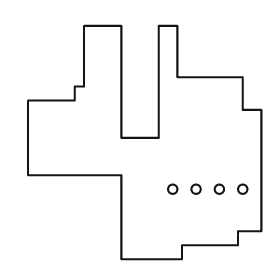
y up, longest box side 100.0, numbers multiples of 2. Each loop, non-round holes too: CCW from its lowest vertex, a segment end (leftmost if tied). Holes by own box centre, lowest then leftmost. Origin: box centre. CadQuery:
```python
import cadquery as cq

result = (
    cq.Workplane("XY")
    .moveTo(-10.0, -50.0)
    .lineTo(16.0, -50.0)
    .lineTo(16.0, -44.0)
    .lineTo(40.0, -44.0)
    .lineTo(40.0, -38.0)
    .lineTo(50.0, -38.0)
    .lineTo(50.0, 14.0)
    .lineTo(42.0, 14.0)
    .lineTo(42.0, 28.0)
    .lineTo(14.0, 28.0)
    .lineTo(14.0, 50.0)
    .lineTo(6.0, 50.0)
    .lineTo(6.0, 2.0)
    .lineTo(-10.0, 2.0)
    .lineTo(-10.0, 50.0)
    .lineTo(-26.0, 50.0)
    .lineTo(-26.0, 24.0)
    .lineTo(-30.0, 24.0)
    .lineTo(-30.0, 18.0)
    .lineTo(-50.0, 18.0)
    .lineTo(-50.0, -14.0)
    .lineTo(-10.0, -14.0)
    .close()
    .moveTo(12.0, -20.0)
    .circle(2.0)
    .moveTo(22.0, -20.0)
    .circle(2.0)
    .moveTo(32.0, -20.0)
    .circle(2.0)
    .moveTo(42.0, -20.0)
    .circle(2.0)
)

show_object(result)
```